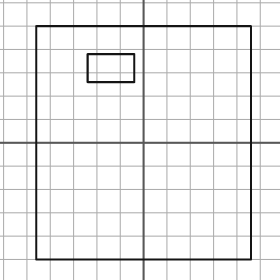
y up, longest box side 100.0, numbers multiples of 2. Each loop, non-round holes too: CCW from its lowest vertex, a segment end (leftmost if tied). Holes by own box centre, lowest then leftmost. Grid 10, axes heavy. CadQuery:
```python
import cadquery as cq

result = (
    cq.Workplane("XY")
    .moveTo(-46.0, -50.0)
    .lineTo(46.0, -50.0)
    .lineTo(46.0, 50.0)
    .lineTo(-46.0, 50.0)
    .close()
    .moveTo(-24.0, 26.0)
    .lineTo(-4.0, 26.0)
    .lineTo(-4.0, 38.0)
    .lineTo(-24.0, 38.0)
    .close()
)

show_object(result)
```